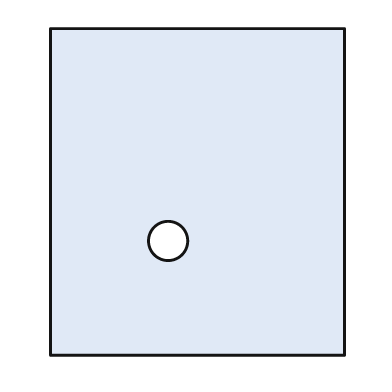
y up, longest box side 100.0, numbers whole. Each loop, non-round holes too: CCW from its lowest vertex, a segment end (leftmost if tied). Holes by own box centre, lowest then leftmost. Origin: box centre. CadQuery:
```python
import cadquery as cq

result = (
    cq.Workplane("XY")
    .moveTo(-45.0, -50.0)
    .lineTo(45.0, -50.0)
    .lineTo(45.0, 50.0)
    .lineTo(-45.0, 50.0)
    .close()
    .moveTo(-9.0, -15.0)
    .circle(6.0)
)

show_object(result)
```